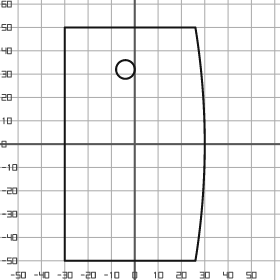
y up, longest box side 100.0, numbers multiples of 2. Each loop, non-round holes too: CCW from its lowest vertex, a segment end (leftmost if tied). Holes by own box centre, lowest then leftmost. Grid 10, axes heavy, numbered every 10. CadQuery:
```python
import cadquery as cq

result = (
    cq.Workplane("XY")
    .moveTo(-30.0, -50.0)
    .lineTo(26.0, -50.0)
    .threePointArc((30.0, 0.0), (26.0, 50.0))
    .lineTo(-30.0, 50.0)
    .close()
    .moveTo(-4.0, 32.0)
    .circle(4.0)
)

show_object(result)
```